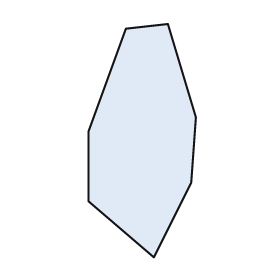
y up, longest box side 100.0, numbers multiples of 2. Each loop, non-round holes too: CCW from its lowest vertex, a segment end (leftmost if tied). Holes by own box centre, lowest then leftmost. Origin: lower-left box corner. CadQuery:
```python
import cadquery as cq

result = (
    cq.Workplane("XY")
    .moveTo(28.0, 0.0)
    .lineTo(44.0, 32.0)
    .lineTo(46.0, 60.0)
    .lineTo(34.0, 100.0)
    .lineTo(16.0, 98.0)
    .lineTo(0.0, 54.0)
    .lineTo(0.0, 24.0)
    .close()
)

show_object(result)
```